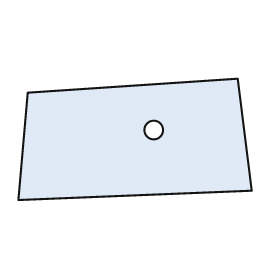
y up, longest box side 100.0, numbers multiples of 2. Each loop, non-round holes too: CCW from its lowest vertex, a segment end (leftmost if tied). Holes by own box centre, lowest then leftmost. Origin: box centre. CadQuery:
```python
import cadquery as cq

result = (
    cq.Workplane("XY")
    .moveTo(-50.0, -26.0)
    .lineTo(50.0, -22.0)
    .lineTo(44.0, 26.0)
    .lineTo(-46.0, 20.0)
    .close()
    .moveTo(8.0, 4.0)
    .circle(4.0)
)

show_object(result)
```